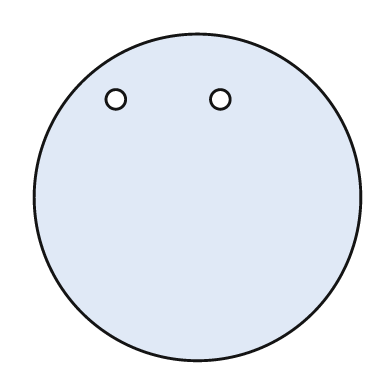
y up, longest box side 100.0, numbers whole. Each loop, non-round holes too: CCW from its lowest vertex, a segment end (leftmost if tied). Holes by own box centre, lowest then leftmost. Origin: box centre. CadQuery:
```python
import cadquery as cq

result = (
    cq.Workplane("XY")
    .moveTo(0.0, 0.0)
    .circle(50.0)
    .moveTo(-25.0, 30.0)
    .circle(3.0)
    .moveTo(7.0, 30.0)
    .circle(3.0)
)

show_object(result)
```